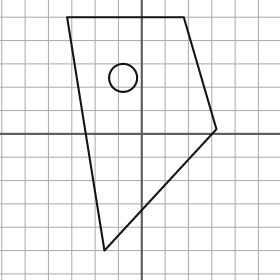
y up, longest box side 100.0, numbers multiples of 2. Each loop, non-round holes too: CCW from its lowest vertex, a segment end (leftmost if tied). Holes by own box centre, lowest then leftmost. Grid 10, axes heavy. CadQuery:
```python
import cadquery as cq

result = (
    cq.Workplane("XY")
    .moveTo(-16.0, -50.0)
    .lineTo(32.0, 2.0)
    .lineTo(18.0, 50.0)
    .lineTo(-32.0, 50.0)
    .close()
    .moveTo(-8.0, 24.0)
    .circle(6.0)
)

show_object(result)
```